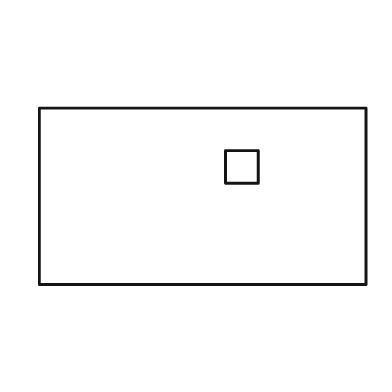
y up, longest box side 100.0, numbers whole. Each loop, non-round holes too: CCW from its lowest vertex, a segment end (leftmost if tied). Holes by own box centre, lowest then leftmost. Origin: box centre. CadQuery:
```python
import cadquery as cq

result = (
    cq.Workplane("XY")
    .moveTo(-50.0, -27.0)
    .lineTo(50.0, -27.0)
    .lineTo(50.0, 27.0)
    .lineTo(-50.0, 27.0)
    .close()
    .moveTo(7.0, 4.0)
    .lineTo(17.0, 4.0)
    .lineTo(17.0, 14.0)
    .lineTo(7.0, 14.0)
    .close()
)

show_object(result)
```